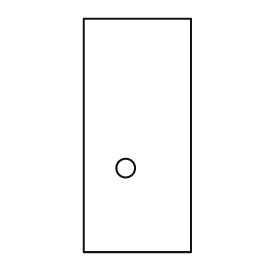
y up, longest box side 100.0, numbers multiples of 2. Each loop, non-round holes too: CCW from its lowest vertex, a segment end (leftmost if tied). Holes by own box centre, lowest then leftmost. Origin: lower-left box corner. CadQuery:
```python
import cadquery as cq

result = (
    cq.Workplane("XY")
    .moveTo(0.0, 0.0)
    .lineTo(46.0, 0.0)
    .lineTo(46.0, 100.0)
    .lineTo(0.0, 100.0)
    .close()
    .moveTo(18.0, 36.0)
    .circle(4.0)
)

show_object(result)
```